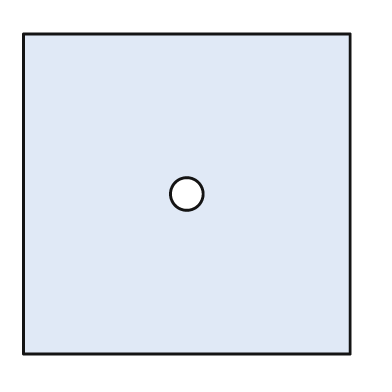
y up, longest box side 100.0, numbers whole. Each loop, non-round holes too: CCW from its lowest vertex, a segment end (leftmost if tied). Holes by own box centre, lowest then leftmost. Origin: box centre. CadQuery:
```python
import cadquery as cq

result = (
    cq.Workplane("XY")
    .moveTo(-50.0, -49.0)
    .lineTo(50.0, -49.0)
    .lineTo(50.0, 49.0)
    .lineTo(-50.0, 49.0)
    .close()
    .moveTo(0.0, 0.0)
    .circle(5.0)
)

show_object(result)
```